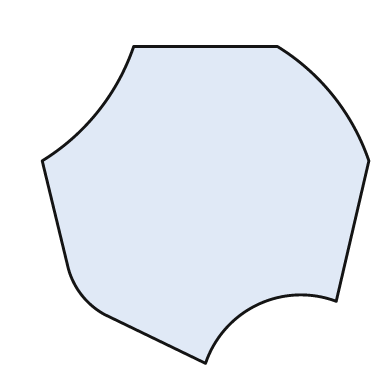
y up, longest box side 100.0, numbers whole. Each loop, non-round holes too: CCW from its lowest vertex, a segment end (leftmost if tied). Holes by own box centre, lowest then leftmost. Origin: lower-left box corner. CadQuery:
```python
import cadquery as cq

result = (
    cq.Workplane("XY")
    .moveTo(50.0, 0.0)
    .threePointArc((66.0, 18.0), (90.0, 19.0))
    .lineTo(100.0, 62.0)
    .threePointArc((89.0, 82.0), (72.0, 97.0))
    .lineTo(28.0, 97.0)
    .threePointArc((17.0, 77.0), (0.0, 62.0))
    .lineTo(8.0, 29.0)
    .threePointArc((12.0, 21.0), (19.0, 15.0))
    .close()
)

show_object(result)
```